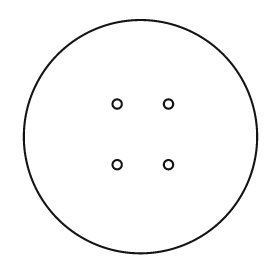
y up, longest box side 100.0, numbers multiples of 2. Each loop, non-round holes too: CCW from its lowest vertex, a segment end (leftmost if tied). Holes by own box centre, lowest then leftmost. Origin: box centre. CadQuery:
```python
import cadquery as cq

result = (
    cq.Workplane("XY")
    .moveTo(0.0, 0.0)
    .circle(50.0)
    .moveTo(-10.0, -12.0)
    .circle(2.0)
    .moveTo(12.0, -12.0)
    .circle(2.0)
    .moveTo(-10.0, 14.0)
    .circle(2.0)
    .moveTo(12.0, 14.0)
    .circle(2.0)
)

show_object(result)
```